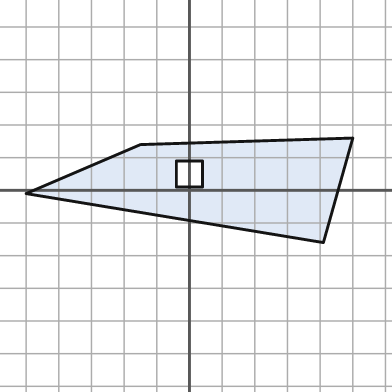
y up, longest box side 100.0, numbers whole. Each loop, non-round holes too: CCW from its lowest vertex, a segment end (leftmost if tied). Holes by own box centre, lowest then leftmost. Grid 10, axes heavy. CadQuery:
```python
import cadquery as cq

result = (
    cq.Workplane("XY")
    .moveTo(41.0, -16.0)
    .lineTo(50.0, 16.0)
    .lineTo(-15.0, 14.0)
    .lineTo(-50.0, -1.0)
    .close()
    .moveTo(-4.0, 1.0)
    .lineTo(4.0, 1.0)
    .lineTo(4.0, 9.0)
    .lineTo(-4.0, 9.0)
    .close()
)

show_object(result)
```